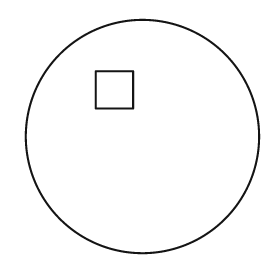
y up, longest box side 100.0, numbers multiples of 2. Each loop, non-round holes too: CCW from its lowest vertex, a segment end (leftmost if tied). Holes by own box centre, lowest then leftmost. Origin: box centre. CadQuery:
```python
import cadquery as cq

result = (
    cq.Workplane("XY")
    .moveTo(0.0, 0.0)
    .circle(50.0)
    .moveTo(-20.0, 12.0)
    .lineTo(-4.0, 12.0)
    .lineTo(-4.0, 28.0)
    .lineTo(-20.0, 28.0)
    .close()
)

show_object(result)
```